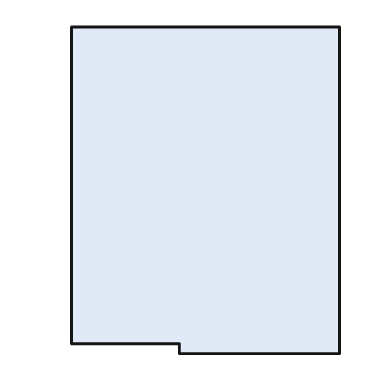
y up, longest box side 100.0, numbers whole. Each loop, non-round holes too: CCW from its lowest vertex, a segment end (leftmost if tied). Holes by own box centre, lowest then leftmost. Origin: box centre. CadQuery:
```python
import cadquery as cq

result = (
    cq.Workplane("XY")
    .moveTo(-8.0, -50.0)
    .lineTo(41.0, -50.0)
    .lineTo(41.0, 50.0)
    .lineTo(-41.0, 50.0)
    .lineTo(-41.0, -47.0)
    .lineTo(-8.0, -47.0)
    .close()
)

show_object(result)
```